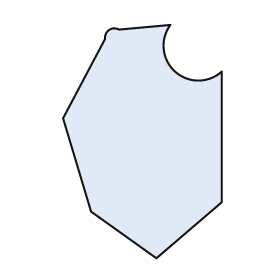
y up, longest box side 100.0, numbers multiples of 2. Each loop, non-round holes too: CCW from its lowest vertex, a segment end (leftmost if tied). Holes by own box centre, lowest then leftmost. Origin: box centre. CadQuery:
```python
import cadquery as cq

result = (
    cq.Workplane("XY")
    .moveTo(6.0, -50.0)
    .lineTo(34.0, -26.0)
    .lineTo(34.0, 30.0)
    .threePointArc((14.0, 30.0), (12.0, 50.0))
    .lineTo(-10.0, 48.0)
    .threePointArc((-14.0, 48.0), (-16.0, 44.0))
    .lineTo(-34.0, 10.0)
    .lineTo(-22.0, -30.0)
    .close()
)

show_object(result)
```